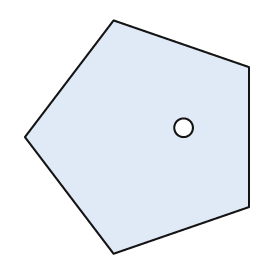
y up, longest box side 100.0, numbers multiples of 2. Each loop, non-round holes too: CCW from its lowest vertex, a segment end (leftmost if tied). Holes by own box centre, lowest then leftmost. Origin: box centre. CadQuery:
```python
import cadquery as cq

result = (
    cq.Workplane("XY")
    .moveTo(-10.0, -50.0)
    .lineTo(48.0, -30.0)
    .lineTo(48.0, 30.0)
    .lineTo(-10.0, 50.0)
    .lineTo(-48.0, 0.0)
    .close()
    .moveTo(20.0, 4.0)
    .circle(4.0)
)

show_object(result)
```